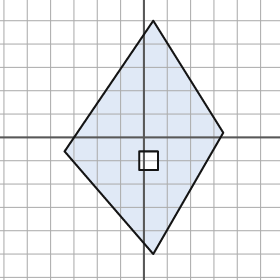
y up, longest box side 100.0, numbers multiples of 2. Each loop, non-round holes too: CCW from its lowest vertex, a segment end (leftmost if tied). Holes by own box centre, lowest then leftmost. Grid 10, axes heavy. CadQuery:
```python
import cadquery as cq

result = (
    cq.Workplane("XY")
    .moveTo(4.0, -50.0)
    .lineTo(34.0, 2.0)
    .lineTo(4.0, 50.0)
    .lineTo(-34.0, -6.0)
    .close()
    .moveTo(-2.0, -14.0)
    .lineTo(6.0, -14.0)
    .lineTo(6.0, -6.0)
    .lineTo(-2.0, -6.0)
    .close()
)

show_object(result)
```